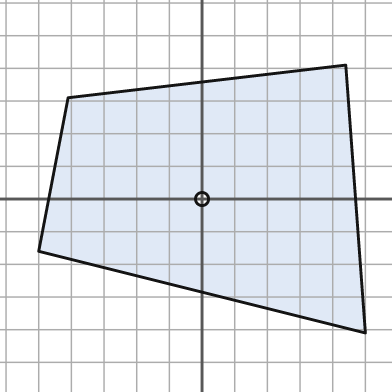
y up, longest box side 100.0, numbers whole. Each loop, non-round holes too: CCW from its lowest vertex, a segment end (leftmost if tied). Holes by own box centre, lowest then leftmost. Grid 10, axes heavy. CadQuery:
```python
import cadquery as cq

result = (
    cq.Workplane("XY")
    .moveTo(50.0, -41.0)
    .lineTo(44.0, 41.0)
    .lineTo(-41.0, 31.0)
    .lineTo(-50.0, -16.0)
    .close()
    .moveTo(0.0, 0.0)
    .circle(2.0)
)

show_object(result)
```